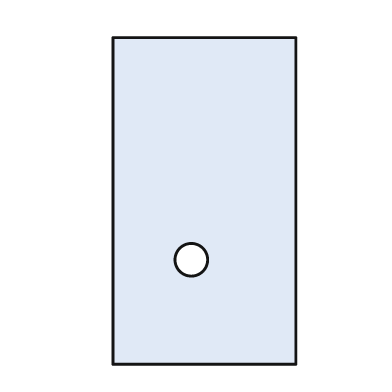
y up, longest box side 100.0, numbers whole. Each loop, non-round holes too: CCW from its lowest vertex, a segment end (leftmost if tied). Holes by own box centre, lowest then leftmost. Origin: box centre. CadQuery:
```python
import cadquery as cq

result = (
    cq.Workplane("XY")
    .moveTo(-28.0, -50.0)
    .lineTo(28.0, -50.0)
    .lineTo(28.0, 50.0)
    .lineTo(-28.0, 50.0)
    .close()
    .moveTo(-4.0, -18.0)
    .circle(5.0)
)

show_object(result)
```